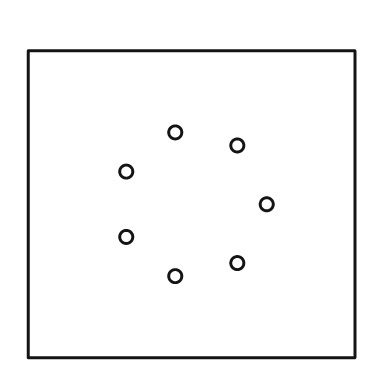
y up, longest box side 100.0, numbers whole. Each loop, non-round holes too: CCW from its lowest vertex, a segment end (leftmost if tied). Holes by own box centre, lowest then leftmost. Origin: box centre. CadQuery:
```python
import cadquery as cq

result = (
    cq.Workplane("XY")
    .moveTo(-50.0, -47.0)
    .lineTo(50.0, -47.0)
    .lineTo(50.0, 47.0)
    .lineTo(-50.0, 47.0)
    .close()
    .moveTo(-5.0, -22.0)
    .circle(2.0)
    .moveTo(14.0, -18.0)
    .circle(2.0)
    .moveTo(-20.0, -10.0)
    .circle(2.0)
    .moveTo(23.0, 0.0)
    .circle(2.0)
    .moveTo(-20.0, 10.0)
    .circle(2.0)
    .moveTo(14.0, 18.0)
    .circle(2.0)
    .moveTo(-5.0, 22.0)
    .circle(2.0)
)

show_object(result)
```